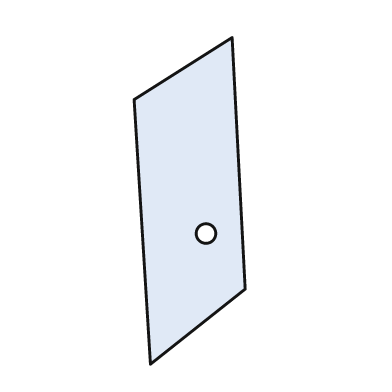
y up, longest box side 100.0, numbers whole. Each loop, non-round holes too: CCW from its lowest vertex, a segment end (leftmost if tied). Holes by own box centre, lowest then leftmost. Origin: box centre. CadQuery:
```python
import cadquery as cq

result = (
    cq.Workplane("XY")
    .moveTo(-12.0, -50.0)
    .lineTo(17.0, -27.0)
    .lineTo(13.0, 50.0)
    .lineTo(-17.0, 31.0)
    .close()
    .moveTo(5.0, -10.0)
    .circle(3.0)
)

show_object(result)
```